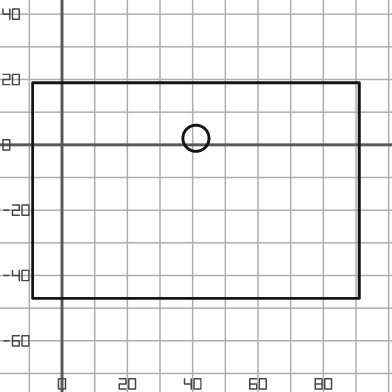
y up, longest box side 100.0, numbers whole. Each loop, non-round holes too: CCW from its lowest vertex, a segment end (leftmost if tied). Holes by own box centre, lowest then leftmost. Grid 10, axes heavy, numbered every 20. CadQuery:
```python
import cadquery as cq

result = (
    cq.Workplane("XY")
    .moveTo(-9.0, -47.0)
    .lineTo(91.0, -47.0)
    .lineTo(91.0, 19.0)
    .lineTo(-9.0, 19.0)
    .close()
    .moveTo(41.0, 2.0)
    .circle(4.0)
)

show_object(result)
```